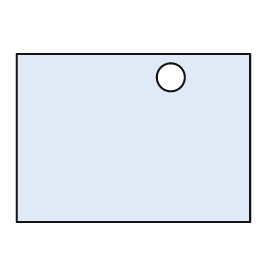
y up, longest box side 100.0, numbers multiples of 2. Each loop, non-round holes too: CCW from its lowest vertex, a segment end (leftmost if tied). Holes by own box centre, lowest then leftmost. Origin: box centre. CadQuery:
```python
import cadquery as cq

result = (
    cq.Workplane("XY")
    .moveTo(-50.0, -36.0)
    .lineTo(50.0, -36.0)
    .lineTo(50.0, 36.0)
    .lineTo(-50.0, 36.0)
    .close()
    .moveTo(16.0, 26.0)
    .circle(6.0)
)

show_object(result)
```